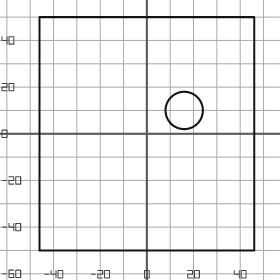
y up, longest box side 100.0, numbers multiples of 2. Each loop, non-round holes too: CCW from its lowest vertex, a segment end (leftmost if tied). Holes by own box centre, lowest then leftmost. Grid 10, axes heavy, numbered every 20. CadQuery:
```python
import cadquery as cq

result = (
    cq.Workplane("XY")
    .moveTo(-46.0, -50.0)
    .lineTo(46.0, -50.0)
    .lineTo(46.0, 50.0)
    .lineTo(-46.0, 50.0)
    .close()
    .moveTo(16.0, 10.0)
    .circle(8.0)
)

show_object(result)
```